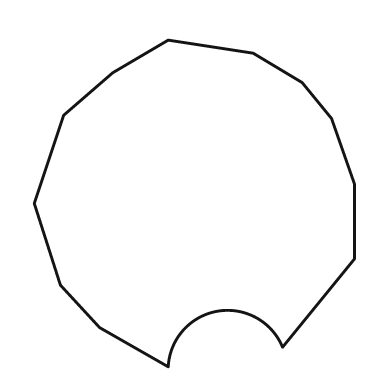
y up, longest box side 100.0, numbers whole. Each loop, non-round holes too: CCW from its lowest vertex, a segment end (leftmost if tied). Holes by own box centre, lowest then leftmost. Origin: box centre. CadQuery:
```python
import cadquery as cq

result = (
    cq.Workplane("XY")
    .moveTo(-8.0, -50.0)
    .threePointArc((7.0, -33.0), (27.0, -44.0))
    .lineTo(49.0, -17.0)
    .lineTo(49.0, 6.0)
    .lineTo(42.0, 26.0)
    .lineTo(33.0, 37.0)
    .lineTo(18.0, 46.0)
    .lineTo(-8.0, 50.0)
    .lineTo(-25.0, 40.0)
    .lineTo(-40.0, 27.0)
    .lineTo(-49.0, 0.0)
    .lineTo(-41.0, -25.0)
    .lineTo(-29.0, -38.0)
    .close()
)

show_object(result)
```